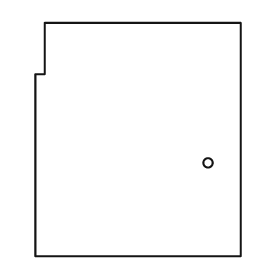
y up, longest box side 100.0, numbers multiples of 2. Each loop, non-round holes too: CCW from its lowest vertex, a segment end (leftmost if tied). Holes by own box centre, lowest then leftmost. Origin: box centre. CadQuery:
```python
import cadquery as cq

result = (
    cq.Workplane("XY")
    .moveTo(-44.0, -50.0)
    .lineTo(44.0, -50.0)
    .lineTo(44.0, 50.0)
    .lineTo(-40.0, 50.0)
    .lineTo(-40.0, 28.0)
    .lineTo(-44.0, 28.0)
    .close()
    .moveTo(30.0, -10.0)
    .circle(2.0)
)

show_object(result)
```